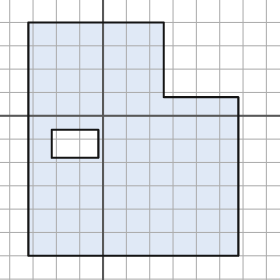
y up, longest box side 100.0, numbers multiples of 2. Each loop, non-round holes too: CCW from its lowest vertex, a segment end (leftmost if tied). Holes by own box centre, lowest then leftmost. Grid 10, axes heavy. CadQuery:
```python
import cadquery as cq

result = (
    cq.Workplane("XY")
    .moveTo(-32.0, -60.0)
    .lineTo(58.0, -60.0)
    .lineTo(58.0, 8.0)
    .lineTo(26.0, 8.0)
    .lineTo(26.0, 40.0)
    .lineTo(-32.0, 40.0)
    .close()
    .moveTo(-22.0, -18.0)
    .lineTo(-2.0, -18.0)
    .lineTo(-2.0, -6.0)
    .lineTo(-22.0, -6.0)
    .close()
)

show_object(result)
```